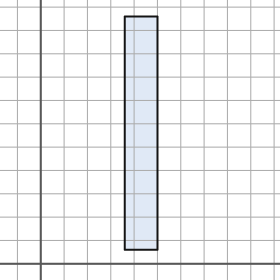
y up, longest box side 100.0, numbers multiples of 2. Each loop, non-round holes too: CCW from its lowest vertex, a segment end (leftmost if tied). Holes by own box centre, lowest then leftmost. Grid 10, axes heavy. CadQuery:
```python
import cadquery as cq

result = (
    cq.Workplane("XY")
    .moveTo(36.0, 6.0)
    .lineTo(50.0, 6.0)
    .lineTo(50.0, 106.0)
    .lineTo(36.0, 106.0)
    .close()
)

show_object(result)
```